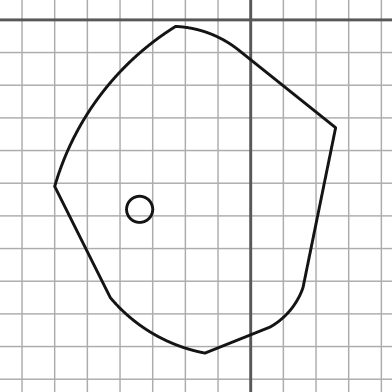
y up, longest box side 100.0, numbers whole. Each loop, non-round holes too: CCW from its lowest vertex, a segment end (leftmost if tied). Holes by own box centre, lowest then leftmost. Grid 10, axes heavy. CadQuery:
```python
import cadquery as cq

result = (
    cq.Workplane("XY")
    .moveTo(-14.0, -102.0)
    .lineTo(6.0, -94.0)
    .threePointArc((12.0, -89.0), (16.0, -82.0))
    .lineTo(26.0, -33.0)
    .lineTo(-4.0, -9.0)
    .threePointArc((-13.0, -4.0), (-23.0, -2.0))
    .threePointArc((-46.0, -23.0), (-60.0, -51.0))
    .lineTo(-43.0, -85.0)
    .threePointArc((-30.0, -96.0), (-14.0, -102.0))
    .close()
    .moveTo(-34.0, -58.0)
    .circle(4.0)
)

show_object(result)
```